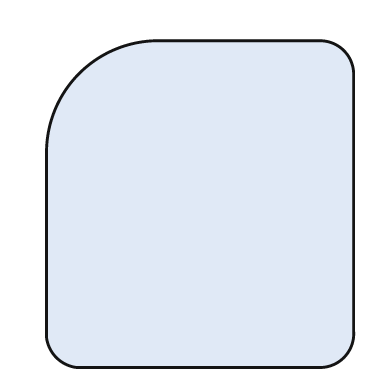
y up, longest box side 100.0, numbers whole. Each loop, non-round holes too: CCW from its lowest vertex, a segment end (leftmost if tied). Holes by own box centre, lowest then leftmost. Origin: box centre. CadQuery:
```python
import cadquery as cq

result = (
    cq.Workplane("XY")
    .moveTo(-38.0, -50.0)
    .lineTo(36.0, -50.0)
    .threePointArc((44.0, -47.0), (47.0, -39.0))
    .lineTo(47.0, 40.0)
    .threePointArc((44.0, 47.0), (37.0, 50.0))
    .lineTo(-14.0, 50.0)
    .threePointArc((-37.0, 40.0), (-47.0, 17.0))
    .lineTo(-47.0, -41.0)
    .threePointArc((-44.0, -47.0), (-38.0, -50.0))
    .close()
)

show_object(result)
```